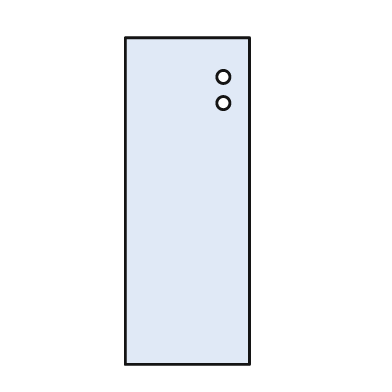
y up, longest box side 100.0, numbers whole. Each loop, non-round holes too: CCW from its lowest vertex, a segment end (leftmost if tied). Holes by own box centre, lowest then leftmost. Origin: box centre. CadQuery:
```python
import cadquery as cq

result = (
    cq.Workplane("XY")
    .moveTo(-19.0, -50.0)
    .lineTo(19.0, -50.0)
    .lineTo(19.0, 50.0)
    .lineTo(-19.0, 50.0)
    .close()
    .moveTo(11.0, 30.0)
    .circle(2.0)
    .moveTo(11.0, 38.0)
    .circle(2.0)
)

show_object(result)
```